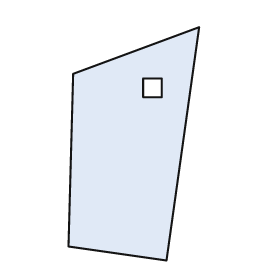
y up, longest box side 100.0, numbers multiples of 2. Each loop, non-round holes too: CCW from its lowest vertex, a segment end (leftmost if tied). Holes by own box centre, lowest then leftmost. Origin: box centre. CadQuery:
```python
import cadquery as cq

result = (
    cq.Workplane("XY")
    .moveTo(14.0, -50.0)
    .lineTo(28.0, 50.0)
    .lineTo(-26.0, 30.0)
    .lineTo(-28.0, -44.0)
    .close()
    .moveTo(4.0, 20.0)
    .lineTo(12.0, 20.0)
    .lineTo(12.0, 28.0)
    .lineTo(4.0, 28.0)
    .close()
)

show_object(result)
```